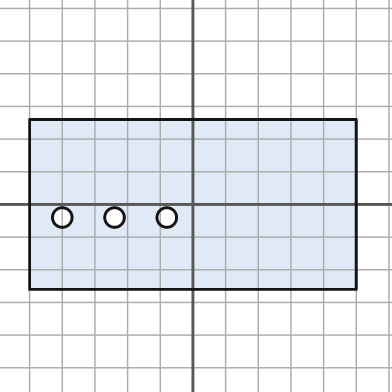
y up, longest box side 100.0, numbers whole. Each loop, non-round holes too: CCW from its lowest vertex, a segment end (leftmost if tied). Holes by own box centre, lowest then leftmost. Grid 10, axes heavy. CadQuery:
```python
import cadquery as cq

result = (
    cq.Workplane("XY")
    .moveTo(-50.0, -26.0)
    .lineTo(50.0, -26.0)
    .lineTo(50.0, 26.0)
    .lineTo(-50.0, 26.0)
    .close()
    .moveTo(-40.0, -4.0)
    .circle(3.0)
    .moveTo(-24.0, -4.0)
    .circle(3.0)
    .moveTo(-8.0, -4.0)
    .circle(3.0)
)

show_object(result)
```